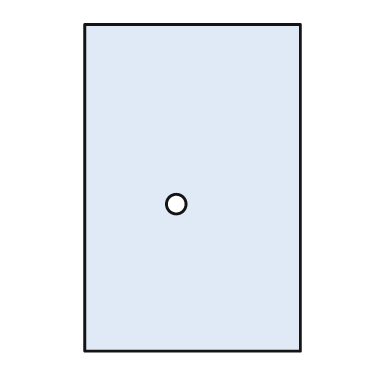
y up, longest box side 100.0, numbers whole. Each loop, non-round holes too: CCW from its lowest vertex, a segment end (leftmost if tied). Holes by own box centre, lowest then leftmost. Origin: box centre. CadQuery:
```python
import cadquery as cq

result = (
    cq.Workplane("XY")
    .moveTo(-33.0, -50.0)
    .lineTo(33.0, -50.0)
    .lineTo(33.0, 50.0)
    .lineTo(-33.0, 50.0)
    .close()
    .moveTo(-5.0, -5.0)
    .circle(3.0)
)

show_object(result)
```